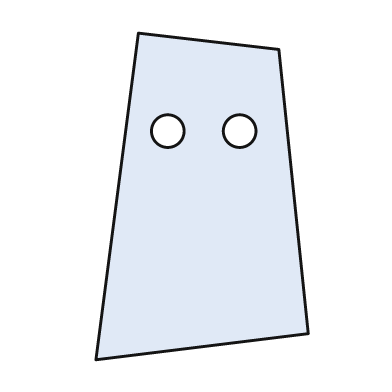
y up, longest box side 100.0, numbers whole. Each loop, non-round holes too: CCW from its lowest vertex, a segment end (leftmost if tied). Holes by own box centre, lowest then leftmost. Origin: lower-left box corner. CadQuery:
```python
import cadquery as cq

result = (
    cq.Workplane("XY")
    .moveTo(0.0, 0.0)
    .lineTo(65.0, 8.0)
    .lineTo(56.0, 95.0)
    .lineTo(13.0, 100.0)
    .close()
    .moveTo(22.0, 70.0)
    .circle(5.0)
    .moveTo(44.0, 70.0)
    .circle(5.0)
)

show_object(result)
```